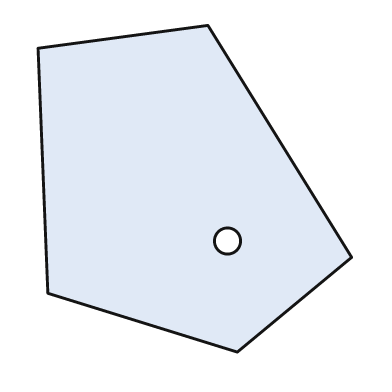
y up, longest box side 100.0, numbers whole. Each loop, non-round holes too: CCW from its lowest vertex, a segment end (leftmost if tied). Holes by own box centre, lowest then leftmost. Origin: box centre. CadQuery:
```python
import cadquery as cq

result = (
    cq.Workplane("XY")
    .moveTo(13.0, -50.0)
    .lineTo(48.0, -21.0)
    .lineTo(4.0, 50.0)
    .lineTo(-48.0, 43.0)
    .lineTo(-45.0, -32.0)
    .close()
    .moveTo(10.0, -16.0)
    .circle(4.0)
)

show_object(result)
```